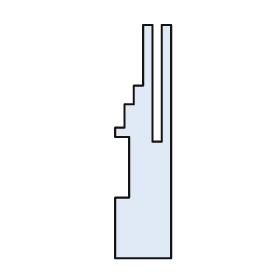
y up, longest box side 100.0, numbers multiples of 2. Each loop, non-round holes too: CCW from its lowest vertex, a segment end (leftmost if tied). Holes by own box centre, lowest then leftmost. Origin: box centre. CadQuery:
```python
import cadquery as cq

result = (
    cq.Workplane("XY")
    .moveTo(-12.0, -50.0)
    .lineTo(12.0, -50.0)
    .lineTo(12.0, 50.0)
    .lineTo(8.0, 50.0)
    .lineTo(8.0, 0.0)
    .lineTo(4.0, 0.0)
    .lineTo(4.0, 50.0)
    .lineTo(0.0, 50.0)
    .lineTo(0.0, 24.0)
    .lineTo(-4.0, 24.0)
    .lineTo(-4.0, 16.0)
    .lineTo(-8.0, 16.0)
    .lineTo(-8.0, 6.0)
    .lineTo(-12.0, 6.0)
    .lineTo(-12.0, 2.0)
    .lineTo(-6.0, 2.0)
    .lineTo(-6.0, -24.0)
    .lineTo(-12.0, -24.0)
    .close()
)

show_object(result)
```